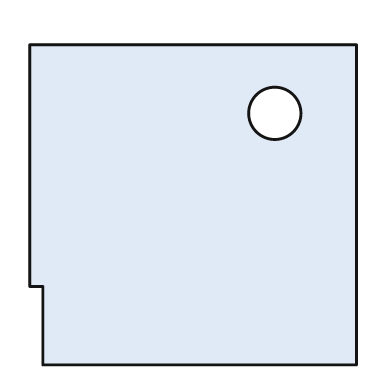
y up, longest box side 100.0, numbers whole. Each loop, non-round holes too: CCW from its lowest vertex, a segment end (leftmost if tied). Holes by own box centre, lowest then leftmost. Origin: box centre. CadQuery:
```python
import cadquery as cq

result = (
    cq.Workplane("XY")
    .moveTo(-46.0, -49.0)
    .lineTo(50.0, -49.0)
    .lineTo(50.0, 49.0)
    .lineTo(-50.0, 49.0)
    .lineTo(-50.0, -25.0)
    .lineTo(-46.0, -25.0)
    .close()
    .moveTo(25.0, 28.0)
    .circle(8.0)
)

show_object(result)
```